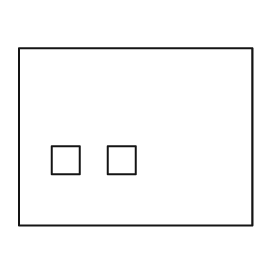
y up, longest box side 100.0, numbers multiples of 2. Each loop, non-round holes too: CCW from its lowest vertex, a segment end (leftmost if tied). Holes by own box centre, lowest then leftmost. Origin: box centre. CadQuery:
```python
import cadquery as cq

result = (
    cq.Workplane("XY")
    .moveTo(-50.0, -38.0)
    .lineTo(50.0, -38.0)
    .lineTo(50.0, 38.0)
    .lineTo(-50.0, 38.0)
    .close()
    .moveTo(-36.0, -16.0)
    .lineTo(-24.0, -16.0)
    .lineTo(-24.0, -4.0)
    .lineTo(-36.0, -4.0)
    .close()
    .moveTo(-12.0, -16.0)
    .lineTo(0.0, -16.0)
    .lineTo(0.0, -4.0)
    .lineTo(-12.0, -4.0)
    .close()
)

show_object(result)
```